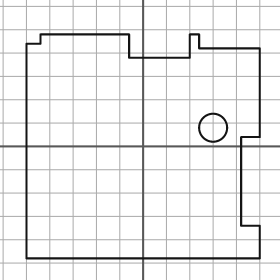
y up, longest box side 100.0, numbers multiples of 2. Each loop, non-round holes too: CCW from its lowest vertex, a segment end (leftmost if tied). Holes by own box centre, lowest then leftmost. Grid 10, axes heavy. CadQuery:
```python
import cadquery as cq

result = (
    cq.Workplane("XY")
    .moveTo(-50.0, -48.0)
    .lineTo(50.0, -48.0)
    .lineTo(50.0, -34.0)
    .lineTo(42.0, -34.0)
    .lineTo(42.0, 4.0)
    .lineTo(50.0, 4.0)
    .lineTo(50.0, 42.0)
    .lineTo(24.0, 42.0)
    .lineTo(24.0, 48.0)
    .lineTo(20.0, 48.0)
    .lineTo(20.0, 38.0)
    .lineTo(-6.0, 38.0)
    .lineTo(-6.0, 48.0)
    .lineTo(-44.0, 48.0)
    .lineTo(-44.0, 44.0)
    .lineTo(-50.0, 44.0)
    .close()
    .moveTo(30.0, 8.0)
    .circle(6.0)
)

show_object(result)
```